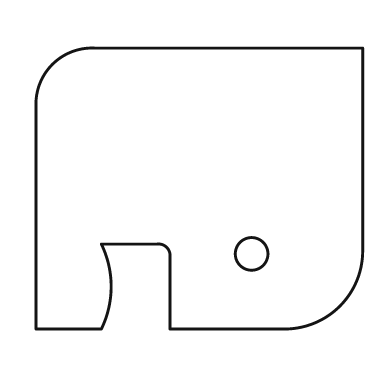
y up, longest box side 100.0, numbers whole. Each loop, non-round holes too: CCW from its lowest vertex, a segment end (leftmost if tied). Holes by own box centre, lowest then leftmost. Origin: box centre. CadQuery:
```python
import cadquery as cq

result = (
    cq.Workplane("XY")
    .moveTo(-50.0, -43.0)
    .lineTo(-30.0, -43.0)
    .threePointArc((-27.0, -30.0), (-30.0, -17.0))
    .lineTo(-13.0, -17.0)
    .threePointArc((-10.0, -18.0), (-9.0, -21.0))
    .lineTo(-9.0, -43.0)
    .lineTo(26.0, -43.0)
    .threePointArc((43.0, -36.0), (50.0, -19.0))
    .lineTo(50.0, 43.0)
    .lineTo(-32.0, 43.0)
    .threePointArc((-45.0, 38.0), (-50.0, 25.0))
    .close()
    .moveTo(16.0, -20.0)
    .circle(5.0)
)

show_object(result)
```